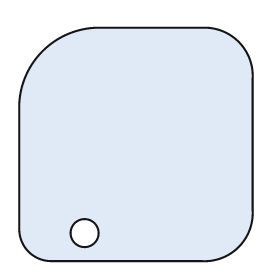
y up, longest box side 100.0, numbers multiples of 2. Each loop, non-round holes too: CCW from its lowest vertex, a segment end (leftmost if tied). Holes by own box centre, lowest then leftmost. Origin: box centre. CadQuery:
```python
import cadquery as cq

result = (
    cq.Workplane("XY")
    .moveTo(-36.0, -50.0)
    .lineTo(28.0, -50.0)
    .threePointArc((44.0, -44.0), (50.0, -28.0))
    .lineTo(50.0, 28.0)
    .threePointArc((44.0, 44.0), (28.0, 50.0))
    .lineTo(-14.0, 50.0)
    .threePointArc((-40.0, 40.0), (-50.0, 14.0))
    .lineTo(-50.0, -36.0)
    .threePointArc((-46.0, -46.0), (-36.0, -50.0))
    .close()
    .moveTo(-22.0, -38.0)
    .circle(6.0)
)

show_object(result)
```